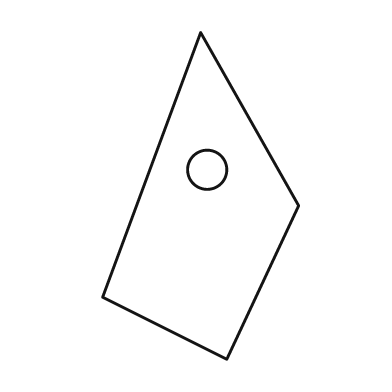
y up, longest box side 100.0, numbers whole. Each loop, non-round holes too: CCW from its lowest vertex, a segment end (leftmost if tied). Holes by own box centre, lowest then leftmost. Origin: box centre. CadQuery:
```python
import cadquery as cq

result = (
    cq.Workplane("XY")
    .moveTo(8.0, -50.0)
    .lineTo(30.0, -3.0)
    .lineTo(0.0, 50.0)
    .lineTo(-30.0, -31.0)
    .close()
    .moveTo(2.0, 8.0)
    .circle(6.0)
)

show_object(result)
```